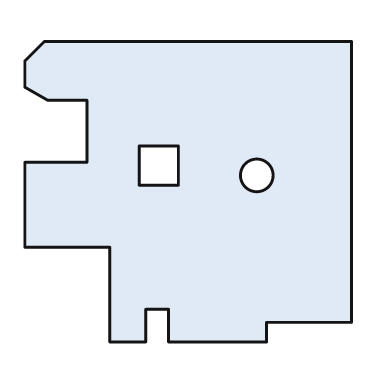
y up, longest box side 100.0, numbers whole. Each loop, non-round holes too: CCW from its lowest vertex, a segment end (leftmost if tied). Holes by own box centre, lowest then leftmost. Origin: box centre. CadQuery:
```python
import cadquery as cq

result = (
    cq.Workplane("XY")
    .moveTo(-24.0, -46.0)
    .lineTo(-13.0, -46.0)
    .lineTo(-13.0, -36.0)
    .lineTo(-6.0, -36.0)
    .lineTo(-6.0, -46.0)
    .lineTo(24.0, -46.0)
    .lineTo(24.0, -40.0)
    .lineTo(50.0, -40.0)
    .lineTo(50.0, 46.0)
    .lineTo(-44.0, 46.0)
    .lineTo(-50.0, 40.0)
    .lineTo(-50.0, 32.0)
    .lineTo(-43.0, 28.0)
    .lineTo(-31.0, 28.0)
    .lineTo(-31.0, 9.0)
    .lineTo(-50.0, 9.0)
    .lineTo(-50.0, -17.0)
    .lineTo(-24.0, -17.0)
    .close()
    .moveTo(21.0, 5.0)
    .circle(5.0)
    .moveTo(-15.0, 2.0)
    .lineTo(-3.0, 2.0)
    .lineTo(-3.0, 14.0)
    .lineTo(-15.0, 14.0)
    .close()
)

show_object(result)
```